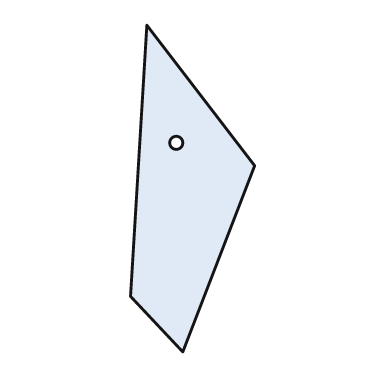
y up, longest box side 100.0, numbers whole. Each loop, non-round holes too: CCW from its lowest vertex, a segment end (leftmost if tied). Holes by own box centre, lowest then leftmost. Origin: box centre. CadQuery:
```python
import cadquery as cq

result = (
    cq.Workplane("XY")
    .moveTo(-3.0, -50.0)
    .lineTo(19.0, 7.0)
    .lineTo(-14.0, 50.0)
    .lineTo(-19.0, -33.0)
    .close()
    .moveTo(-5.0, 14.0)
    .circle(2.0)
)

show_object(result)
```